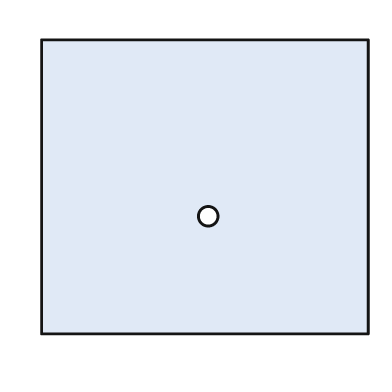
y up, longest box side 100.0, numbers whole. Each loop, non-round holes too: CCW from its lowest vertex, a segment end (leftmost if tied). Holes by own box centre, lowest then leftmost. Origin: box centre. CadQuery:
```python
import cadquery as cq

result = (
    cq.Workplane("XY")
    .moveTo(-50.0, -45.0)
    .lineTo(50.0, -45.0)
    .lineTo(50.0, 45.0)
    .lineTo(-50.0, 45.0)
    .close()
    .moveTo(1.0, -9.0)
    .circle(3.0)
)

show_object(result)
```